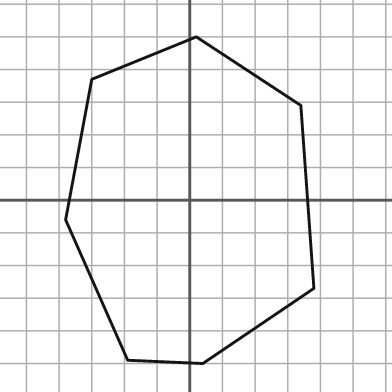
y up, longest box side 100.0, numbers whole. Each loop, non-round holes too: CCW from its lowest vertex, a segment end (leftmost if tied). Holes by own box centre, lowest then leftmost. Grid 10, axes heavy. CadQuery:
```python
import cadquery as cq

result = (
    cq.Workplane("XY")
    .moveTo(4.0, -50.0)
    .lineTo(38.0, -27.0)
    .lineTo(34.0, 29.0)
    .lineTo(2.0, 50.0)
    .lineTo(-30.0, 37.0)
    .lineTo(-38.0, -6.0)
    .lineTo(-19.0, -49.0)
    .close()
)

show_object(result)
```